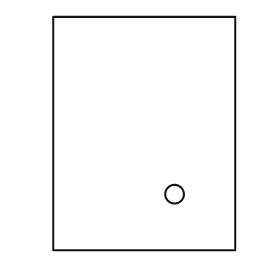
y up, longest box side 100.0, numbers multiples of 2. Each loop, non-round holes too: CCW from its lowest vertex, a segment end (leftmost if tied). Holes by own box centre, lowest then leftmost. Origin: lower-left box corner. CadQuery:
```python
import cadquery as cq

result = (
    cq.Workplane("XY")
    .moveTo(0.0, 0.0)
    .lineTo(78.0, 0.0)
    .lineTo(78.0, 100.0)
    .lineTo(0.0, 100.0)
    .close()
    .moveTo(52.0, 24.0)
    .circle(4.0)
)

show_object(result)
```